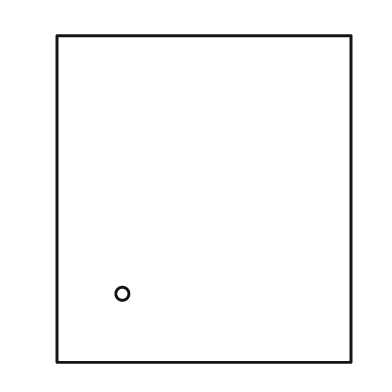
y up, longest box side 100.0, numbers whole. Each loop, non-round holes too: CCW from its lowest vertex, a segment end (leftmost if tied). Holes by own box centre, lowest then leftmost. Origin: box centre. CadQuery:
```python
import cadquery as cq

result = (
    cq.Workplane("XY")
    .moveTo(-45.0, -50.0)
    .lineTo(45.0, -50.0)
    .lineTo(45.0, 50.0)
    .lineTo(-45.0, 50.0)
    .close()
    .moveTo(-25.0, -29.0)
    .circle(2.0)
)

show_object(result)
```